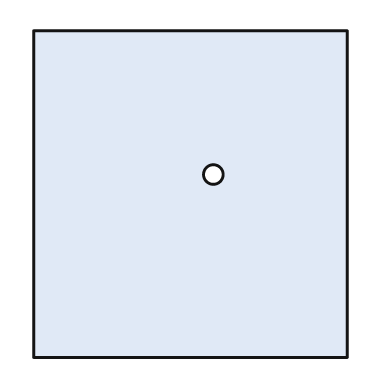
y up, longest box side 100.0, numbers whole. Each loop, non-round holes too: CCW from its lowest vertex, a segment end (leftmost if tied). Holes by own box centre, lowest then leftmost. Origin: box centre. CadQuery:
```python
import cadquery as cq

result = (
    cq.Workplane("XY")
    .moveTo(-48.0, -50.0)
    .lineTo(48.0, -50.0)
    .lineTo(48.0, 50.0)
    .lineTo(-48.0, 50.0)
    .close()
    .moveTo(7.0, 6.0)
    .circle(3.0)
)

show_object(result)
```